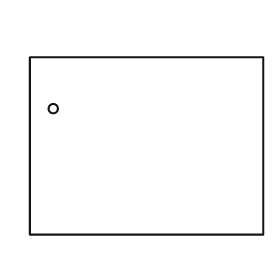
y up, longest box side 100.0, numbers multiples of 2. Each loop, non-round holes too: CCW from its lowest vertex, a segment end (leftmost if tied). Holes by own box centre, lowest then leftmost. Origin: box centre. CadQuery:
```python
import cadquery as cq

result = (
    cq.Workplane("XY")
    .moveTo(-50.0, -38.0)
    .lineTo(50.0, -38.0)
    .lineTo(50.0, 38.0)
    .lineTo(-50.0, 38.0)
    .close()
    .moveTo(-40.0, 16.0)
    .circle(2.0)
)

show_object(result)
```